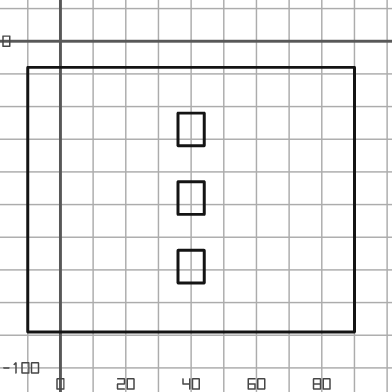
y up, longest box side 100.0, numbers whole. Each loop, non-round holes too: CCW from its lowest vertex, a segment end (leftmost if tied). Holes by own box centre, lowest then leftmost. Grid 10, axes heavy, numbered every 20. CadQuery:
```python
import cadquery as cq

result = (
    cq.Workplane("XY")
    .moveTo(-10.0, -89.0)
    .lineTo(90.0, -89.0)
    .lineTo(90.0, -8.0)
    .lineTo(-10.0, -8.0)
    .close()
    .moveTo(36.0, -74.0)
    .lineTo(44.0, -74.0)
    .lineTo(44.0, -64.0)
    .lineTo(36.0, -64.0)
    .close()
    .moveTo(36.0, -53.0)
    .lineTo(44.0, -53.0)
    .lineTo(44.0, -43.0)
    .lineTo(36.0, -43.0)
    .close()
    .moveTo(36.0, -32.0)
    .lineTo(44.0, -32.0)
    .lineTo(44.0, -22.0)
    .lineTo(36.0, -22.0)
    .close()
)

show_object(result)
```